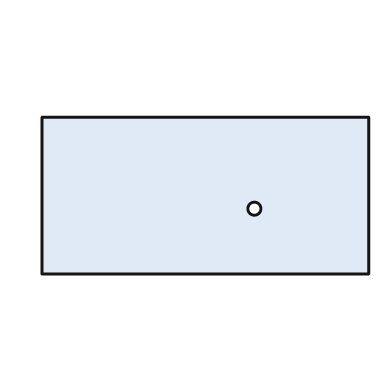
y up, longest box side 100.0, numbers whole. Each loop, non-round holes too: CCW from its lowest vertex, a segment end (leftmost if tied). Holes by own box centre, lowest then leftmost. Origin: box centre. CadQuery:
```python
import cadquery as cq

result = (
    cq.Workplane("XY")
    .moveTo(-50.0, -24.0)
    .lineTo(50.0, -24.0)
    .lineTo(50.0, 24.0)
    .lineTo(-50.0, 24.0)
    .close()
    .moveTo(15.0, -4.0)
    .circle(2.0)
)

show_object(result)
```